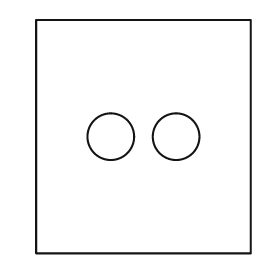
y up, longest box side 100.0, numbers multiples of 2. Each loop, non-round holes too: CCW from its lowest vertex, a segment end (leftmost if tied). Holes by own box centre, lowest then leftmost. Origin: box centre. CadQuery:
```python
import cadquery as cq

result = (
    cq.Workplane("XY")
    .moveTo(-46.0, -50.0)
    .lineTo(46.0, -50.0)
    .lineTo(46.0, 50.0)
    .lineTo(-46.0, 50.0)
    .close()
    .moveTo(-14.0, 0.0)
    .circle(10.0)
    .moveTo(14.0, 0.0)
    .circle(10.0)
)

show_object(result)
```